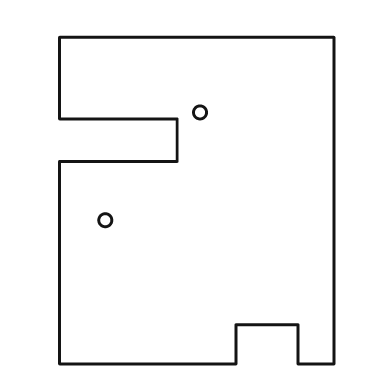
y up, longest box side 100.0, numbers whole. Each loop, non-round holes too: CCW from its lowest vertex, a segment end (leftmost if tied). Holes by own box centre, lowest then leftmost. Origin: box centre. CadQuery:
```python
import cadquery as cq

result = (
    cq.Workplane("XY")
    .moveTo(-42.0, -50.0)
    .lineTo(12.0, -50.0)
    .lineTo(12.0, -38.0)
    .lineTo(31.0, -38.0)
    .lineTo(31.0, -50.0)
    .lineTo(42.0, -50.0)
    .lineTo(42.0, 50.0)
    .lineTo(-42.0, 50.0)
    .lineTo(-42.0, 25.0)
    .lineTo(-6.0, 25.0)
    .lineTo(-6.0, 12.0)
    .lineTo(-42.0, 12.0)
    .close()
    .moveTo(-28.0, -6.0)
    .circle(2.0)
    .moveTo(1.0, 27.0)
    .circle(2.0)
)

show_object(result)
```